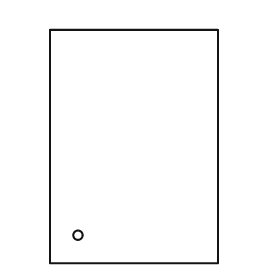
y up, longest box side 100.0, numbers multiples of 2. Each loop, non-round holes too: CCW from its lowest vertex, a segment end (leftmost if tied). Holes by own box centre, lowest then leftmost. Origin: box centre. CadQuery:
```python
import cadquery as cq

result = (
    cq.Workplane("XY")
    .moveTo(-36.0, -50.0)
    .lineTo(36.0, -50.0)
    .lineTo(36.0, 50.0)
    .lineTo(-36.0, 50.0)
    .close()
    .moveTo(-24.0, -38.0)
    .circle(2.0)
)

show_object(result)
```